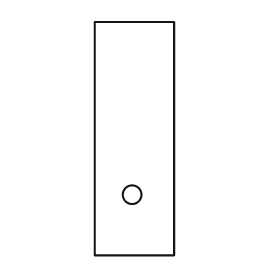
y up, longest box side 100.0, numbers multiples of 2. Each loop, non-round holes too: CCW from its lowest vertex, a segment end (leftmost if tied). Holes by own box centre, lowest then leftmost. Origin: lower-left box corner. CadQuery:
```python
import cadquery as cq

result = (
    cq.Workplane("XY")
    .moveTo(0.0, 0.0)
    .lineTo(34.0, 0.0)
    .lineTo(34.0, 100.0)
    .lineTo(0.0, 100.0)
    .close()
    .moveTo(16.0, 26.0)
    .circle(4.0)
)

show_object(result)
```